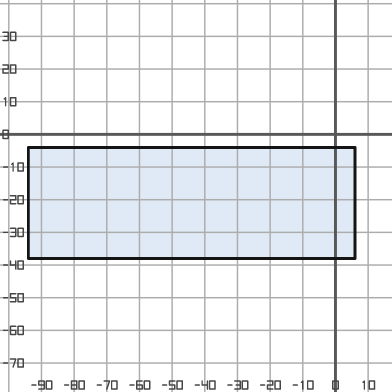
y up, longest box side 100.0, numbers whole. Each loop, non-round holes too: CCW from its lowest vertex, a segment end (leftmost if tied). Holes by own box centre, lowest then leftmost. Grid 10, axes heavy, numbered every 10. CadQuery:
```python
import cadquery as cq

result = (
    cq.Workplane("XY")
    .moveTo(-94.0, -38.0)
    .lineTo(6.0, -38.0)
    .lineTo(6.0, -4.0)
    .lineTo(-94.0, -4.0)
    .close()
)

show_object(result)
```